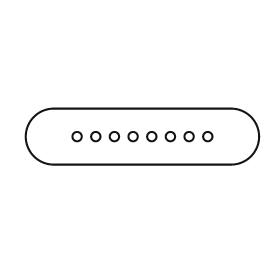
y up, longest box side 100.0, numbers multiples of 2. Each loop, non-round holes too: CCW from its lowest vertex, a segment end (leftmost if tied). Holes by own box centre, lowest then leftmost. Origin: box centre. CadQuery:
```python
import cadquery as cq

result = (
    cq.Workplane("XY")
    .moveTo(-38.0, -12.0)
    .lineTo(38.0, -12.0)
    .threePointArc((50.0, 0.0), (38.0, 12.0))
    .lineTo(-38.0, 12.0)
    .threePointArc((-50.0, 0.0), (-38.0, -12.0))
    .close()
    .moveTo(-28.0, 0.0)
    .circle(2.0)
    .moveTo(-20.0, 0.0)
    .circle(2.0)
    .moveTo(-12.0, 0.0)
    .circle(2.0)
    .moveTo(-4.0, 0.0)
    .circle(2.0)
    .moveTo(4.0, 0.0)
    .circle(2.0)
    .moveTo(12.0, 0.0)
    .circle(2.0)
    .moveTo(20.0, 0.0)
    .circle(2.0)
    .moveTo(28.0, 0.0)
    .circle(2.0)
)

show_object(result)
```